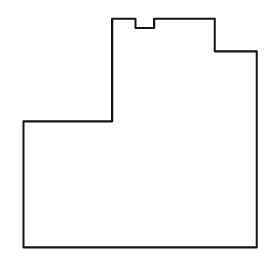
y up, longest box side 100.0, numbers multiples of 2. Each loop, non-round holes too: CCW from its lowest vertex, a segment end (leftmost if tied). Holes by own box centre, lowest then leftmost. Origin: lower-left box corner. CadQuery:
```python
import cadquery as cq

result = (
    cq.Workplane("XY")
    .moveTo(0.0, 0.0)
    .lineTo(100.0, 0.0)
    .lineTo(100.0, 84.0)
    .lineTo(82.0, 84.0)
    .lineTo(82.0, 98.0)
    .lineTo(56.0, 98.0)
    .lineTo(56.0, 94.0)
    .lineTo(48.0, 94.0)
    .lineTo(48.0, 98.0)
    .lineTo(38.0, 98.0)
    .lineTo(38.0, 54.0)
    .lineTo(0.0, 54.0)
    .close()
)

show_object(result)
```